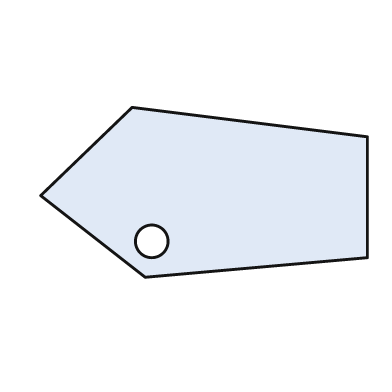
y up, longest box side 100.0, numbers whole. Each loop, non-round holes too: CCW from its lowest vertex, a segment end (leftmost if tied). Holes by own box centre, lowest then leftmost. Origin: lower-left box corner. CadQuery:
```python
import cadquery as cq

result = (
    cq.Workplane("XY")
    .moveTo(32.0, 0.0)
    .lineTo(100.0, 6.0)
    .lineTo(100.0, 43.0)
    .lineTo(28.0, 52.0)
    .lineTo(0.0, 25.0)
    .close()
    .moveTo(34.0, 11.0)
    .circle(5.0)
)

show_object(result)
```